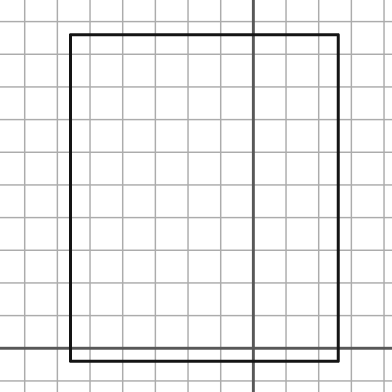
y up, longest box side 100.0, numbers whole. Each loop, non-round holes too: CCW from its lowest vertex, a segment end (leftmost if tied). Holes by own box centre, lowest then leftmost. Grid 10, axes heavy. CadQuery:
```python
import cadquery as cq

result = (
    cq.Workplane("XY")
    .moveTo(-56.0, -4.0)
    .lineTo(26.0, -4.0)
    .lineTo(26.0, 96.0)
    .lineTo(-56.0, 96.0)
    .close()
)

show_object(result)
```